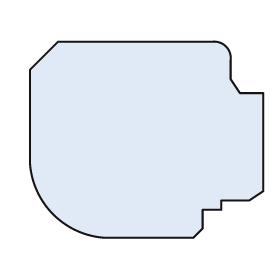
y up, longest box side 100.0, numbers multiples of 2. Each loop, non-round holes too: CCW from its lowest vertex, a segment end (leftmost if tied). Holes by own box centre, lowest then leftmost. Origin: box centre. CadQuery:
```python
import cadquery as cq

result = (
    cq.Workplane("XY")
    .moveTo(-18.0, -42.0)
    .lineTo(20.0, -42.0)
    .lineTo(24.0, -38.0)
    .lineTo(24.0, -30.0)
    .lineTo(32.0, -30.0)
    .lineTo(32.0, -26.0)
    .lineTo(44.0, -26.0)
    .lineTo(50.0, -22.0)
    .lineTo(50.0, 20.0)
    .lineTo(40.0, 20.0)
    .lineTo(36.0, 26.0)
    .lineTo(36.0, 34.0)
    .threePointArc((34.0, 40.0), (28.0, 42.0))
    .lineTo(-38.0, 42.0)
    .lineTo(-50.0, 30.0)
    .lineTo(-50.0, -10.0)
    .threePointArc((-40.0, -32.0), (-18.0, -42.0))
    .close()
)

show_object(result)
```